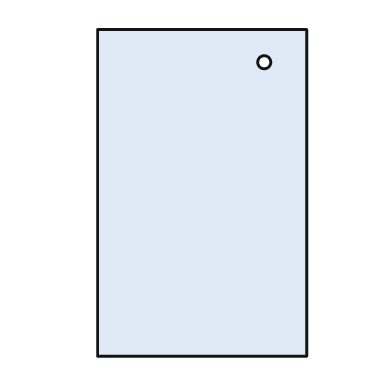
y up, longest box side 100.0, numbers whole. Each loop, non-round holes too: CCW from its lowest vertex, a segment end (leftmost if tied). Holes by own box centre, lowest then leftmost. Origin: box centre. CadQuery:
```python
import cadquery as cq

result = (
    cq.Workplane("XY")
    .moveTo(-32.0, -50.0)
    .lineTo(32.0, -50.0)
    .lineTo(32.0, 50.0)
    .lineTo(-32.0, 50.0)
    .close()
    .moveTo(19.0, 40.0)
    .circle(2.0)
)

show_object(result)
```